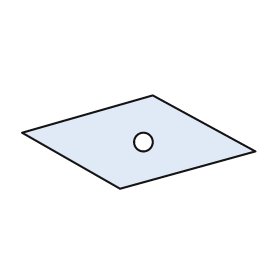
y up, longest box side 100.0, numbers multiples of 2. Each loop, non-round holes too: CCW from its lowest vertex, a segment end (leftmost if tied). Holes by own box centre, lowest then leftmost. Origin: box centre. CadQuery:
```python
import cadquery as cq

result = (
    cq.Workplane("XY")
    .moveTo(-8.0, -20.0)
    .lineTo(50.0, -4.0)
    .lineTo(6.0, 20.0)
    .lineTo(-50.0, 4.0)
    .close()
    .moveTo(2.0, 0.0)
    .circle(4.0)
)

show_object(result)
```